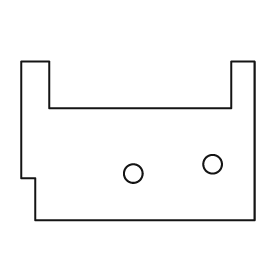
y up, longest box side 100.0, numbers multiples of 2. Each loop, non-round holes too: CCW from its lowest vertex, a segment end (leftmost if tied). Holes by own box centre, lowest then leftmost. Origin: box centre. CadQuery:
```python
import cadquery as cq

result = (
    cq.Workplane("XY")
    .moveTo(-44.0, -34.0)
    .lineTo(50.0, -34.0)
    .lineTo(50.0, 34.0)
    .lineTo(40.0, 34.0)
    .lineTo(40.0, 14.0)
    .lineTo(-38.0, 14.0)
    .lineTo(-38.0, 34.0)
    .lineTo(-50.0, 34.0)
    .lineTo(-50.0, -16.0)
    .lineTo(-44.0, -16.0)
    .close()
    .moveTo(-2.0, -14.0)
    .circle(4.0)
    .moveTo(32.0, -10.0)
    .circle(4.0)
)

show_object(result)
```